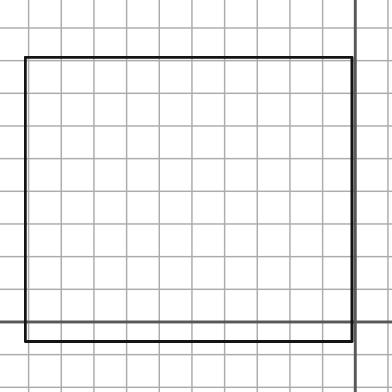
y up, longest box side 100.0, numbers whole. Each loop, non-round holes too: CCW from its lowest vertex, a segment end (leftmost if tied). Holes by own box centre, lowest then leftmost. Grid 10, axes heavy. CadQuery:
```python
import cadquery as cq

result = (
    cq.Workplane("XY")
    .moveTo(-101.0, -6.0)
    .lineTo(-1.0, -6.0)
    .lineTo(-1.0, 81.0)
    .lineTo(-101.0, 81.0)
    .close()
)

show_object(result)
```